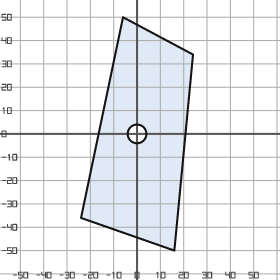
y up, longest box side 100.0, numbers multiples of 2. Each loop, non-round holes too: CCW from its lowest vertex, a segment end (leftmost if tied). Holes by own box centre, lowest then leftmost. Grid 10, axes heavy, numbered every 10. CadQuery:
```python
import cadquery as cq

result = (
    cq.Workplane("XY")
    .moveTo(16.0, -50.0)
    .lineTo(24.0, 34.0)
    .lineTo(-6.0, 50.0)
    .lineTo(-24.0, -36.0)
    .close()
    .moveTo(0.0, 0.0)
    .circle(4.0)
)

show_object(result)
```